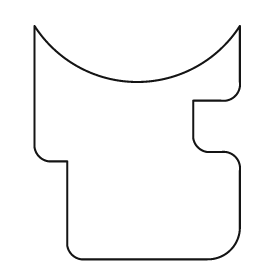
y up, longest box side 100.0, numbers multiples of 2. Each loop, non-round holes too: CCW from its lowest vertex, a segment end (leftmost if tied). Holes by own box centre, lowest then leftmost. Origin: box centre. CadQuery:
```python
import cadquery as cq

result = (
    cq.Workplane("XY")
    .moveTo(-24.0, -50.0)
    .lineTo(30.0, -50.0)
    .threePointArc((40.0, -46.0), (44.0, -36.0))
    .lineTo(44.0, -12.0)
    .threePointArc((42.0, -6.0), (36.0, -4.0))
    .lineTo(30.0, -4.0)
    .threePointArc((26.0, -2.0), (24.0, 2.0))
    .lineTo(24.0, 18.0)
    .lineTo(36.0, 18.0)
    .threePointArc((42.0, 20.0), (44.0, 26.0))
    .lineTo(44.0, 50.0)
    .threePointArc((0.0, 26.0), (-44.0, 50.0))
    .lineTo(-44.0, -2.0)
    .threePointArc((-42.0, -6.0), (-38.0, -8.0))
    .lineTo(-30.0, -8.0)
    .lineTo(-30.0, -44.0)
    .threePointArc((-28.0, -48.0), (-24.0, -50.0))
    .close()
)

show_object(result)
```